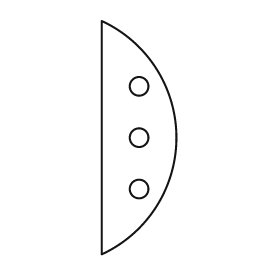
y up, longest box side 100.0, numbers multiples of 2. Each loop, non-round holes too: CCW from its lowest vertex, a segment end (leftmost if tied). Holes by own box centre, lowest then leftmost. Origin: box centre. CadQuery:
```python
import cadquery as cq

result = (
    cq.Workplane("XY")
    .moveTo(-16.0, -50.0)
    .threePointArc((16.0, 0.0), (-16.0, 50.0))
    .close()
    .moveTo(0.0, -22.0)
    .circle(4.0)
    .moveTo(0.0, 0.0)
    .circle(4.0)
    .moveTo(0.0, 22.0)
    .circle(4.0)
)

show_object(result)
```